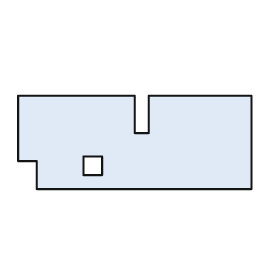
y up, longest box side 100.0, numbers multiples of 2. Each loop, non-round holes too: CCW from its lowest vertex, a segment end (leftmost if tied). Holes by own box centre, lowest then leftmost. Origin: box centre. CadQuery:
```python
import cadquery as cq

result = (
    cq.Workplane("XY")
    .moveTo(-42.0, -20.0)
    .lineTo(50.0, -20.0)
    .lineTo(50.0, 20.0)
    .lineTo(6.0, 20.0)
    .lineTo(6.0, 4.0)
    .lineTo(0.0, 4.0)
    .lineTo(0.0, 20.0)
    .lineTo(-50.0, 20.0)
    .lineTo(-50.0, -8.0)
    .lineTo(-42.0, -8.0)
    .close()
    .moveTo(-22.0, -14.0)
    .lineTo(-14.0, -14.0)
    .lineTo(-14.0, -6.0)
    .lineTo(-22.0, -6.0)
    .close()
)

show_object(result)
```